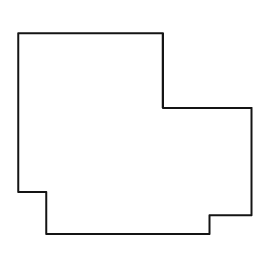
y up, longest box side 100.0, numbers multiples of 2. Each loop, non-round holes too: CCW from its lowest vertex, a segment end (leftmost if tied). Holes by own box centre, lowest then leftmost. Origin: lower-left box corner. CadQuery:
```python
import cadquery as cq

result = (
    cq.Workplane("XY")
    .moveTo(12.0, 0.0)
    .lineTo(82.0, 0.0)
    .lineTo(82.0, 8.0)
    .lineTo(100.0, 8.0)
    .lineTo(100.0, 54.0)
    .lineTo(62.0, 54.0)
    .lineTo(62.0, 86.0)
    .lineTo(0.0, 86.0)
    .lineTo(0.0, 18.0)
    .lineTo(12.0, 18.0)
    .close()
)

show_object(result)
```